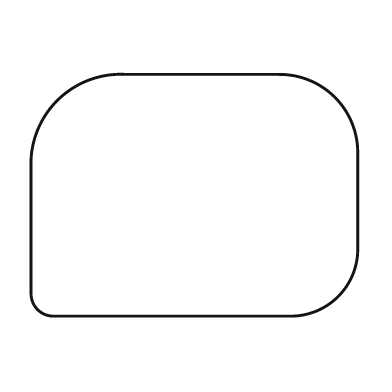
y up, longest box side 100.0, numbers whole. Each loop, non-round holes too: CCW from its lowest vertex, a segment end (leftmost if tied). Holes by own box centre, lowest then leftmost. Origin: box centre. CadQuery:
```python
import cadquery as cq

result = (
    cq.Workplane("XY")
    .moveTo(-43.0, -37.0)
    .lineTo(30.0, -37.0)
    .threePointArc((44.0, -31.0), (50.0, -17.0))
    .lineTo(50.0, 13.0)
    .threePointArc((43.0, 30.0), (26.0, 37.0))
    .lineTo(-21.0, 37.0)
    .threePointArc((-42.0, 29.0), (-50.0, 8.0))
    .lineTo(-50.0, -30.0)
    .threePointArc((-48.0, -35.0), (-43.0, -37.0))
    .close()
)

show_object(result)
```